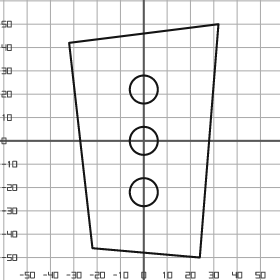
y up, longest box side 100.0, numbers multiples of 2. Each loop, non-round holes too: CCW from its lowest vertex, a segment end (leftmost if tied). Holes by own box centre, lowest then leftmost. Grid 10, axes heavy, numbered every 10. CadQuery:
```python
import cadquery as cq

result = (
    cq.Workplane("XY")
    .moveTo(24.0, -50.0)
    .lineTo(32.0, 50.0)
    .lineTo(-32.0, 42.0)
    .lineTo(-22.0, -46.0)
    .close()
    .moveTo(0.0, -22.0)
    .circle(6.0)
    .moveTo(0.0, 0.0)
    .circle(6.0)
    .moveTo(0.0, 22.0)
    .circle(6.0)
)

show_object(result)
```